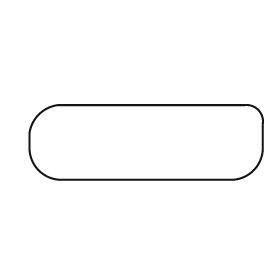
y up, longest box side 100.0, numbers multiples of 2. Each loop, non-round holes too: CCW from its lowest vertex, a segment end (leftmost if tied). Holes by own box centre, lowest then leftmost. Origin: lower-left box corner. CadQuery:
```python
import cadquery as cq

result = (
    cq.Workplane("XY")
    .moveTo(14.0, 0.0)
    .lineTo(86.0, 0.0)
    .threePointArc((96.0, 4.0), (100.0, 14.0))
    .lineTo(100.0, 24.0)
    .threePointArc((98.0, 30.0), (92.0, 32.0))
    .lineTo(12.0, 32.0)
    .threePointArc((4.0, 28.0), (0.0, 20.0))
    .lineTo(0.0, 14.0)
    .threePointArc((4.0, 4.0), (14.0, 0.0))
    .close()
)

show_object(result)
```